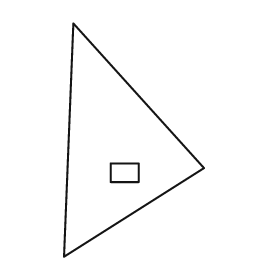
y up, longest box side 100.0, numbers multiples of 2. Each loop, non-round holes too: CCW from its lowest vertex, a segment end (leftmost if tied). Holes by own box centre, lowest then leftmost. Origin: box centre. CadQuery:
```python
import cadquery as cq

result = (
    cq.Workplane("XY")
    .moveTo(-30.0, -50.0)
    .lineTo(30.0, -12.0)
    .lineTo(-26.0, 50.0)
    .close()
    .moveTo(-10.0, -18.0)
    .lineTo(2.0, -18.0)
    .lineTo(2.0, -10.0)
    .lineTo(-10.0, -10.0)
    .close()
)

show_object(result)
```